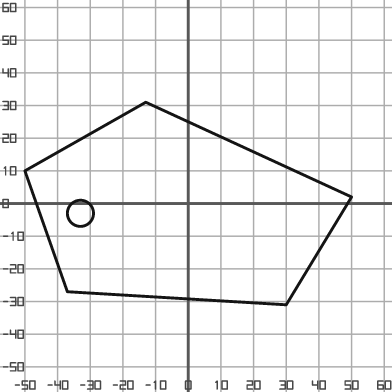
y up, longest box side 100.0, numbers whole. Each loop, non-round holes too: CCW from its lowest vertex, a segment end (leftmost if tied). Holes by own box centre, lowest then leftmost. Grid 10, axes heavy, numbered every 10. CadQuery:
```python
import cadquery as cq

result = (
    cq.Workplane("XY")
    .moveTo(30.0, -31.0)
    .lineTo(50.0, 2.0)
    .lineTo(-13.0, 31.0)
    .lineTo(-50.0, 10.0)
    .lineTo(-37.0, -27.0)
    .close()
    .moveTo(-33.0, -3.0)
    .circle(4.0)
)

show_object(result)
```